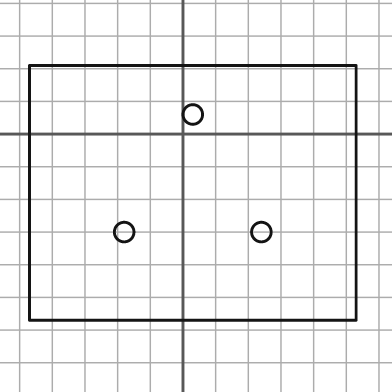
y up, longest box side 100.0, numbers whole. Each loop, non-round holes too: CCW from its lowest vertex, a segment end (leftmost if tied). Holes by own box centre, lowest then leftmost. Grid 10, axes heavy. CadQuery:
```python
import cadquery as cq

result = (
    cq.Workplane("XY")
    .moveTo(-47.0, -57.0)
    .lineTo(53.0, -57.0)
    .lineTo(53.0, 21.0)
    .lineTo(-47.0, 21.0)
    .close()
    .moveTo(-18.0, -30.0)
    .circle(3.0)
    .moveTo(24.0, -30.0)
    .circle(3.0)
    .moveTo(3.0, 6.0)
    .circle(3.0)
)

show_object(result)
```